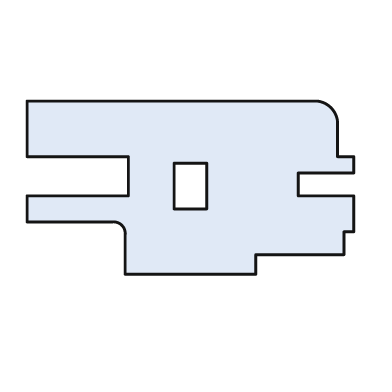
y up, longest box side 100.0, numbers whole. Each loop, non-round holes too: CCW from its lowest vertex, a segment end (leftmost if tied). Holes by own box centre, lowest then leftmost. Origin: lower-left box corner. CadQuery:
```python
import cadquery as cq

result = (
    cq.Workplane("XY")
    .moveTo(30.0, 0.0)
    .lineTo(70.0, 0.0)
    .lineTo(70.0, 6.0)
    .lineTo(97.0, 6.0)
    .lineTo(97.0, 13.0)
    .lineTo(100.0, 13.0)
    .lineTo(100.0, 24.0)
    .lineTo(83.0, 24.0)
    .lineTo(83.0, 31.0)
    .lineTo(100.0, 31.0)
    .lineTo(100.0, 36.0)
    .lineTo(95.0, 36.0)
    .lineTo(95.0, 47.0)
    .threePointArc((93.0, 51.0), (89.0, 53.0))
    .lineTo(0.0, 53.0)
    .lineTo(0.0, 36.0)
    .lineTo(31.0, 36.0)
    .lineTo(31.0, 24.0)
    .lineTo(0.0, 24.0)
    .lineTo(0.0, 16.0)
    .lineTo(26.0, 16.0)
    .threePointArc((29.0, 15.0), (30.0, 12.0))
    .close()
    .moveTo(45.0, 20.0)
    .lineTo(55.0, 20.0)
    .lineTo(55.0, 34.0)
    .lineTo(45.0, 34.0)
    .close()
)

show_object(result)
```